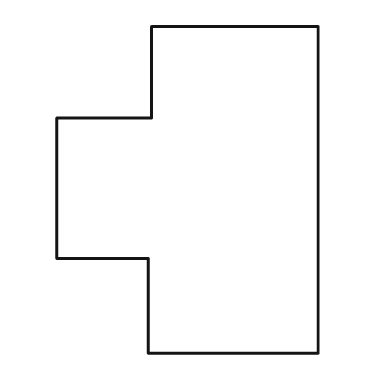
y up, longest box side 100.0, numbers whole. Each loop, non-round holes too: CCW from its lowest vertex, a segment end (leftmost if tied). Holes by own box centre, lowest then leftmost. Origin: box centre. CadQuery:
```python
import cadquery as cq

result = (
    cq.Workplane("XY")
    .moveTo(-12.0, -50.0)
    .lineTo(40.0, -50.0)
    .lineTo(40.0, 50.0)
    .lineTo(-11.0, 50.0)
    .lineTo(-11.0, 22.0)
    .lineTo(-40.0, 22.0)
    .lineTo(-40.0, -21.0)
    .lineTo(-12.0, -21.0)
    .close()
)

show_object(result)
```